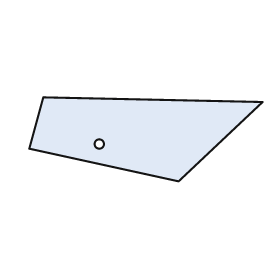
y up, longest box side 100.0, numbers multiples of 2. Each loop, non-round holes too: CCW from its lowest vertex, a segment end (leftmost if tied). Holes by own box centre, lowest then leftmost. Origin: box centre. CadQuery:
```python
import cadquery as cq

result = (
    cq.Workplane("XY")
    .moveTo(14.0, -18.0)
    .lineTo(50.0, 16.0)
    .lineTo(-44.0, 18.0)
    .lineTo(-50.0, -4.0)
    .close()
    .moveTo(-20.0, -2.0)
    .circle(2.0)
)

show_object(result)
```